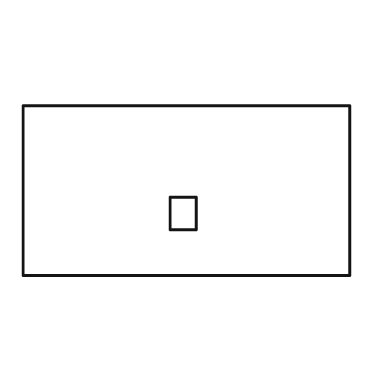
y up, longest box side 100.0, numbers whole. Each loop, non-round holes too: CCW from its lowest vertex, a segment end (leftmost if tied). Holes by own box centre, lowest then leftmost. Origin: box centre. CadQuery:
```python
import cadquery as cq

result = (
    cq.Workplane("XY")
    .moveTo(-50.0, -26.0)
    .lineTo(50.0, -26.0)
    .lineTo(50.0, 26.0)
    .lineTo(-50.0, 26.0)
    .close()
    .moveTo(-5.0, -12.0)
    .lineTo(3.0, -12.0)
    .lineTo(3.0, -2.0)
    .lineTo(-5.0, -2.0)
    .close()
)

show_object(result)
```